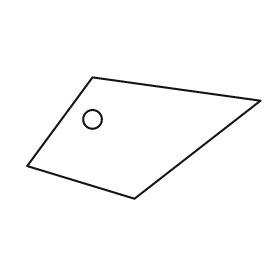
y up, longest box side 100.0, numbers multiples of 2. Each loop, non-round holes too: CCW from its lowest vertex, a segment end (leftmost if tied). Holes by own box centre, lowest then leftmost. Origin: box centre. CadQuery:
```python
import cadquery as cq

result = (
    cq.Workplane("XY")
    .moveTo(-4.0, -26.0)
    .lineTo(50.0, 16.0)
    .lineTo(-22.0, 26.0)
    .lineTo(-50.0, -12.0)
    .close()
    .moveTo(-22.0, 8.0)
    .circle(4.0)
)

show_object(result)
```